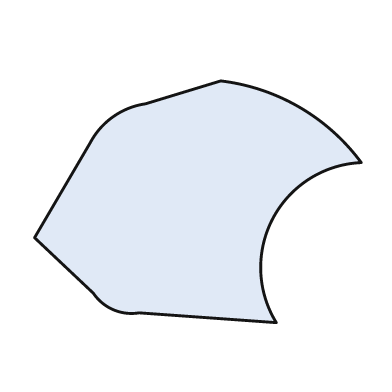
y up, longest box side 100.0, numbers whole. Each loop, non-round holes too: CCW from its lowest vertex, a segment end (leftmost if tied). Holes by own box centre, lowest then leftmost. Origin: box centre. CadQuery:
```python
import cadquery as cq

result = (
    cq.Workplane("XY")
    .moveTo(24.0, -37.0)
    .threePointArc((23.0, -5.0), (50.0, 12.0))
    .threePointArc((31.0, 29.0), (7.0, 37.0))
    .lineTo(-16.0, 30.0)
    .threePointArc((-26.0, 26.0), (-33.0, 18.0))
    .lineTo(-50.0, -11.0)
    .lineTo(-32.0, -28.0)
    .threePointArc((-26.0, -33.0), (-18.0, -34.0))
    .close()
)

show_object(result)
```